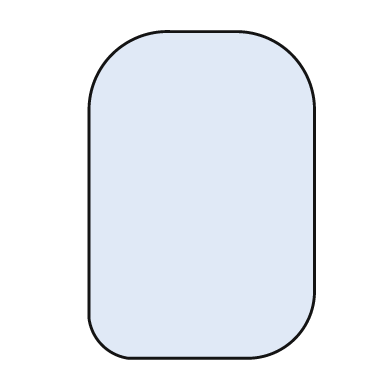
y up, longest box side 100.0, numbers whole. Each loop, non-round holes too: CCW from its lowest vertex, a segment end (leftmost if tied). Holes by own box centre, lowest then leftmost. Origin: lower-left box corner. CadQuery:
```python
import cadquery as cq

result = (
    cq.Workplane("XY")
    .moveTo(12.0, 0.0)
    .lineTo(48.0, 0.0)
    .threePointArc((63.0, 6.0), (69.0, 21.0))
    .lineTo(69.0, 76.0)
    .threePointArc((62.0, 93.0), (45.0, 100.0))
    .lineTo(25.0, 100.0)
    .threePointArc((7.0, 93.0), (0.0, 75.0))
    .lineTo(0.0, 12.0)
    .threePointArc((4.0, 4.0), (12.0, 0.0))
    .close()
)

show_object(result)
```